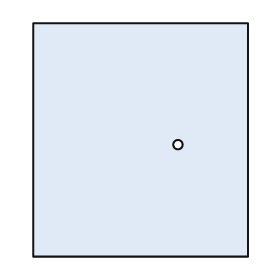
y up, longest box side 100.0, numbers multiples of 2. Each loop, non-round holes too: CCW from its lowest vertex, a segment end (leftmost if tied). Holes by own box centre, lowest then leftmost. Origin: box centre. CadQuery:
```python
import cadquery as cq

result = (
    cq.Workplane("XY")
    .moveTo(-46.0, -50.0)
    .lineTo(46.0, -50.0)
    .lineTo(46.0, 50.0)
    .lineTo(-46.0, 50.0)
    .close()
    .moveTo(16.0, -2.0)
    .circle(2.0)
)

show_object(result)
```